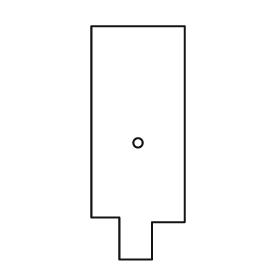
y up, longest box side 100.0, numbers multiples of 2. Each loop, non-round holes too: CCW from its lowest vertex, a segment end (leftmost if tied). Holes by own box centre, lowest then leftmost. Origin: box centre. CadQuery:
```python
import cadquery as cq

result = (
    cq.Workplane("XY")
    .moveTo(-8.0, -50.0)
    .lineTo(6.0, -50.0)
    .lineTo(6.0, -34.0)
    .lineTo(20.0, -34.0)
    .lineTo(20.0, 50.0)
    .lineTo(-20.0, 50.0)
    .lineTo(-20.0, -32.0)
    .lineTo(-8.0, -32.0)
    .close()
    .moveTo(0.0, 0.0)
    .circle(2.0)
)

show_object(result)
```